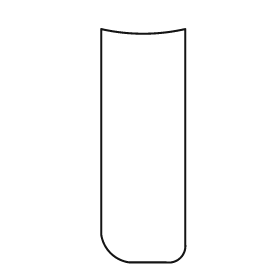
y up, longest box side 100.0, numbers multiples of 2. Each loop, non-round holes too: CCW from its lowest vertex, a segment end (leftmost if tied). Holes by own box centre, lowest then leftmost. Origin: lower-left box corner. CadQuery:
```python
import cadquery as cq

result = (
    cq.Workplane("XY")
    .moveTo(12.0, 0.0)
    .lineTo(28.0, 0.0)
    .threePointArc((34.0, 2.0), (36.0, 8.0))
    .lineTo(36.0, 100.0)
    .threePointArc((18.0, 98.0), (0.0, 100.0))
    .lineTo(0.0, 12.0)
    .threePointArc((4.0, 4.0), (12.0, 0.0))
    .close()
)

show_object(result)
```